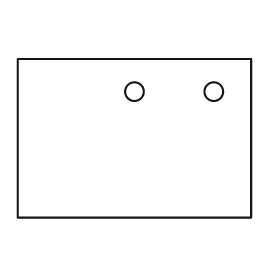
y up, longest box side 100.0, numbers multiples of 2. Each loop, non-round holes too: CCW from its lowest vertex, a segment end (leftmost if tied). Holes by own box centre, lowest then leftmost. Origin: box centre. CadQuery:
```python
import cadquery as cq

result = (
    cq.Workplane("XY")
    .moveTo(-50.0, -34.0)
    .lineTo(50.0, -34.0)
    .lineTo(50.0, 34.0)
    .lineTo(-50.0, 34.0)
    .close()
    .moveTo(0.0, 20.0)
    .circle(4.0)
    .moveTo(34.0, 20.0)
    .circle(4.0)
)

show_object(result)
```